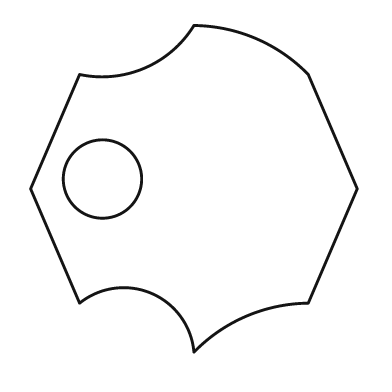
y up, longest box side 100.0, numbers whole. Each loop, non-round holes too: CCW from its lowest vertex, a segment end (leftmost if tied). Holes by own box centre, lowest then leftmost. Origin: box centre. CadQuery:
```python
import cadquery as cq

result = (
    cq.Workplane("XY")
    .moveTo(0.0, -50.0)
    .threePointArc((16.0, -39.0), (35.0, -35.0))
    .lineTo(50.0, 0.0)
    .lineTo(35.0, 35.0)
    .threePointArc((19.0, 46.0), (0.0, 50.0))
    .threePointArc((-15.0, 37.0), (-35.0, 35.0))
    .lineTo(-50.0, 0.0)
    .lineTo(-35.0, -35.0)
    .threePointArc((-13.0, -32.0), (0.0, -50.0))
    .close()
    .moveTo(-28.0, 3.0)
    .circle(12.0)
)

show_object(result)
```